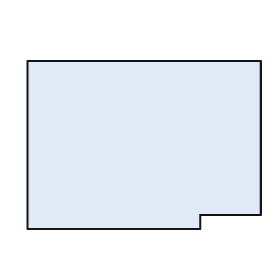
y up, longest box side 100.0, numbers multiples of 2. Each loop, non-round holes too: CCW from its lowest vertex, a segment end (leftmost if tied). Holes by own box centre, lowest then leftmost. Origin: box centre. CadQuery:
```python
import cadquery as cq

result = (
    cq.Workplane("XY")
    .moveTo(-50.0, -36.0)
    .lineTo(24.0, -36.0)
    .lineTo(24.0, -30.0)
    .lineTo(50.0, -30.0)
    .lineTo(50.0, 36.0)
    .lineTo(-50.0, 36.0)
    .close()
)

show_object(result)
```